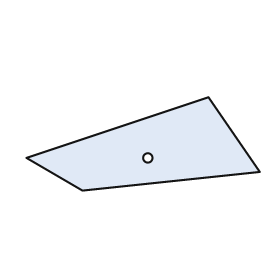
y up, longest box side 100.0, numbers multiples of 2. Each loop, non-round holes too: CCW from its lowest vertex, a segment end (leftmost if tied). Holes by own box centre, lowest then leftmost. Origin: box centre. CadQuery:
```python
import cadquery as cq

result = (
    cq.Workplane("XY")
    .moveTo(-26.0, -20.0)
    .lineTo(50.0, -12.0)
    .lineTo(28.0, 20.0)
    .lineTo(-50.0, -6.0)
    .close()
    .moveTo(2.0, -6.0)
    .circle(2.0)
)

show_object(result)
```